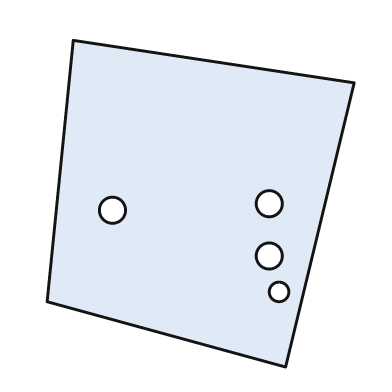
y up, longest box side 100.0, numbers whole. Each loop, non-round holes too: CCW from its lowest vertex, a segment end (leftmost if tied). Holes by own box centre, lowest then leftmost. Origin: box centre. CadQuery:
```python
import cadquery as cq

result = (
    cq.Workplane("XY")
    .moveTo(26.0, -50.0)
    .lineTo(47.0, 37.0)
    .lineTo(-39.0, 50.0)
    .lineTo(-47.0, -30.0)
    .close()
    .moveTo(24.0, -27.0)
    .circle(3.0)
    .moveTo(21.0, -16.0)
    .circle(4.0)
    .moveTo(-27.0, -2.0)
    .circle(4.0)
    .moveTo(21.0, 0.0)
    .circle(4.0)
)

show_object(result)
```